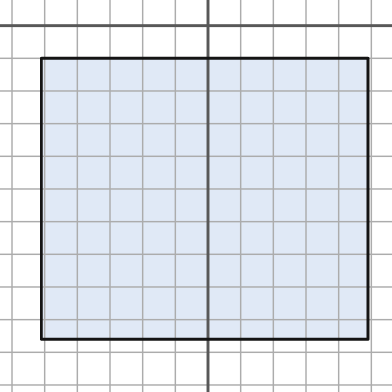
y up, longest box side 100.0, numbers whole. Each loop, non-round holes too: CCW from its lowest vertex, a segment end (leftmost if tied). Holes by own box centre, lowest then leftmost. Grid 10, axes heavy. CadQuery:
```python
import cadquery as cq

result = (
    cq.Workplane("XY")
    .moveTo(-51.0, -96.0)
    .lineTo(49.0, -96.0)
    .lineTo(49.0, -10.0)
    .lineTo(-51.0, -10.0)
    .close()
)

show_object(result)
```